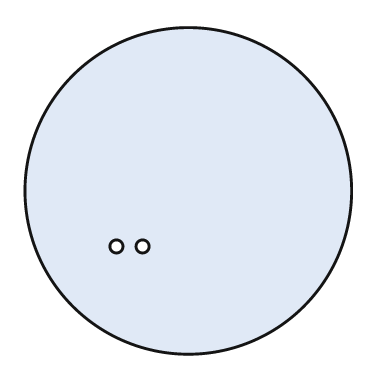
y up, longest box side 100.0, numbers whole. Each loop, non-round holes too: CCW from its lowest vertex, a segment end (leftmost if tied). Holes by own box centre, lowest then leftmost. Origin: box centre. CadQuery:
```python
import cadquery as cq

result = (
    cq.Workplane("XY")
    .moveTo(0.0, 0.0)
    .circle(50.0)
    .moveTo(-22.0, -17.0)
    .circle(2.0)
    .moveTo(-14.0, -17.0)
    .circle(2.0)
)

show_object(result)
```